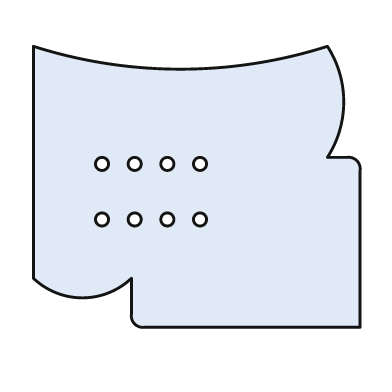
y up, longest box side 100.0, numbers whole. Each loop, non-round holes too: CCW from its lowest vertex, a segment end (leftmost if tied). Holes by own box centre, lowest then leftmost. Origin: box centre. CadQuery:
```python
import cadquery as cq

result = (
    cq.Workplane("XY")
    .moveTo(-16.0, -43.0)
    .lineTo(50.0, -43.0)
    .lineTo(50.0, 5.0)
    .threePointArc((49.0, 8.0), (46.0, 9.0))
    .lineTo(40.0, 9.0)
    .threePointArc((45.0, 26.0), (40.0, 43.0))
    .threePointArc((-5.0, 36.0), (-50.0, 43.0))
    .lineTo(-50.0, -28.0)
    .threePointArc((-35.0, -34.0), (-20.0, -28.0))
    .lineTo(-20.0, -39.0)
    .threePointArc((-19.0, -42.0), (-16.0, -43.0))
    .close()
    .moveTo(-29.0, -10.0)
    .circle(2.0)
    .moveTo(-19.0, -10.0)
    .circle(2.0)
    .moveTo(-9.0, -10.0)
    .circle(2.0)
    .moveTo(1.0, -10.0)
    .circle(2.0)
    .moveTo(-29.0, 7.0)
    .circle(2.0)
    .moveTo(-19.0, 7.0)
    .circle(2.0)
    .moveTo(-9.0, 7.0)
    .circle(2.0)
    .moveTo(1.0, 7.0)
    .circle(2.0)
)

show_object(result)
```